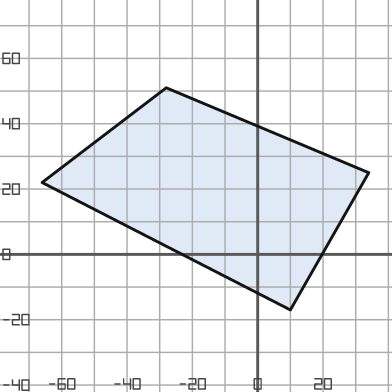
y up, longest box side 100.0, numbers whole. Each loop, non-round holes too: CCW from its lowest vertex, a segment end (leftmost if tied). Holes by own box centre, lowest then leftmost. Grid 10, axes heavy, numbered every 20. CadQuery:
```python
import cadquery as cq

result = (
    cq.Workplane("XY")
    .moveTo(10.0, -17.0)
    .lineTo(34.0, 25.0)
    .lineTo(-28.0, 51.0)
    .lineTo(-66.0, 22.0)
    .close()
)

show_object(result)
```